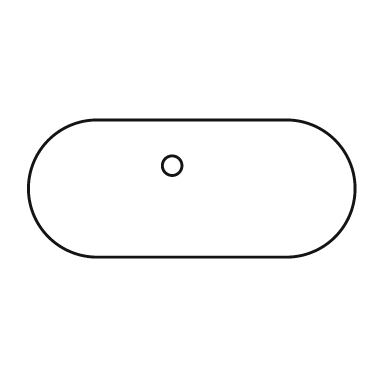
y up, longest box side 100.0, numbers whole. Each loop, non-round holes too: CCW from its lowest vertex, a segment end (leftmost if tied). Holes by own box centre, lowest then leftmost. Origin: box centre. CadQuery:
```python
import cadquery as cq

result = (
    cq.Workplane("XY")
    .moveTo(-29.0, -21.0)
    .lineTo(29.0, -21.0)
    .threePointArc((50.0, 0.0), (29.0, 21.0))
    .lineTo(-29.0, 21.0)
    .threePointArc((-50.0, 0.0), (-29.0, -21.0))
    .close()
    .moveTo(-6.0, 7.0)
    .circle(3.0)
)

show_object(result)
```